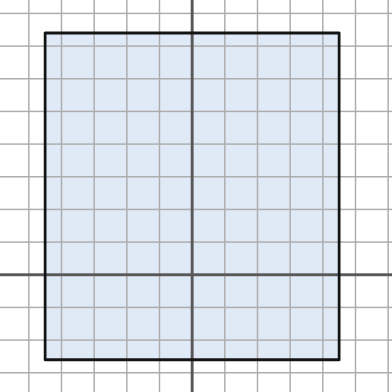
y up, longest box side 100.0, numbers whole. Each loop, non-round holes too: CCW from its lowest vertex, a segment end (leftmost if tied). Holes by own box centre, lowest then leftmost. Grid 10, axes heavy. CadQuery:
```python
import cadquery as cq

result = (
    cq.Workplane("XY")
    .moveTo(-45.0, -26.0)
    .lineTo(45.0, -26.0)
    .lineTo(45.0, 74.0)
    .lineTo(-45.0, 74.0)
    .close()
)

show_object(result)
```